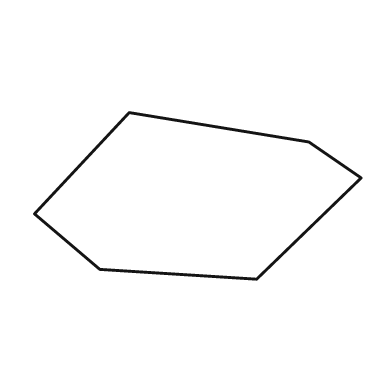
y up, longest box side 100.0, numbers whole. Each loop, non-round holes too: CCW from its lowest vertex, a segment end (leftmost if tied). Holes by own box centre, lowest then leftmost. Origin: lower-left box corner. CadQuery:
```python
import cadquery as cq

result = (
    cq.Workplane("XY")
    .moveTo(68.0, 0.0)
    .lineTo(100.0, 31.0)
    .lineTo(84.0, 42.0)
    .lineTo(29.0, 51.0)
    .lineTo(0.0, 20.0)
    .lineTo(20.0, 3.0)
    .close()
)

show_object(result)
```